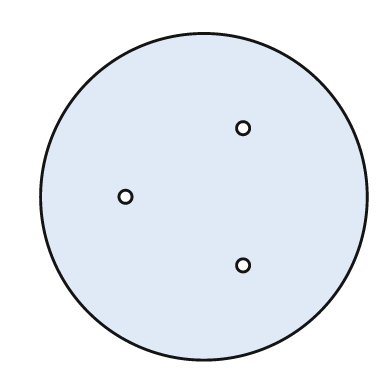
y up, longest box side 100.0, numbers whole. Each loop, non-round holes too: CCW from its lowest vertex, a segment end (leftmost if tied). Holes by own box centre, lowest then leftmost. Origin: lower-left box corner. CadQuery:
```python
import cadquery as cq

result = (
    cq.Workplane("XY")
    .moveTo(50.0, 50.0)
    .circle(50.0)
    .moveTo(62.0, 29.0)
    .circle(2.0)
    .moveTo(26.0, 50.0)
    .circle(2.0)
    .moveTo(62.0, 71.0)
    .circle(2.0)
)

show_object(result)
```